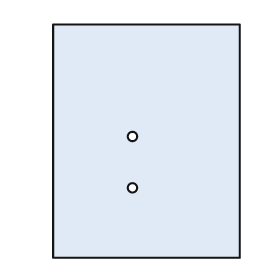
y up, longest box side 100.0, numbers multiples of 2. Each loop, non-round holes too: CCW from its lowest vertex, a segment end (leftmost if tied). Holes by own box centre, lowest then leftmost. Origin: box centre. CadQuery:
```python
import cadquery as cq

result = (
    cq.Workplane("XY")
    .moveTo(-40.0, -50.0)
    .lineTo(40.0, -50.0)
    .lineTo(40.0, 50.0)
    .lineTo(-40.0, 50.0)
    .close()
    .moveTo(-6.0, -20.0)
    .circle(2.0)
    .moveTo(-6.0, 2.0)
    .circle(2.0)
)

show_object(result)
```